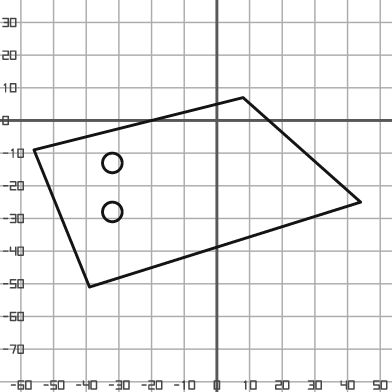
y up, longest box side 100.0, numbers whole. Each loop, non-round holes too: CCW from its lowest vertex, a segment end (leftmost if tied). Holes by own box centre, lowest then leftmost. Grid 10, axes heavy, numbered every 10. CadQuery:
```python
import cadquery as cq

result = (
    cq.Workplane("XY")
    .moveTo(-39.0, -51.0)
    .lineTo(44.0, -25.0)
    .lineTo(8.0, 7.0)
    .lineTo(-56.0, -9.0)
    .close()
    .moveTo(-32.0, -28.0)
    .circle(3.0)
    .moveTo(-32.0, -13.0)
    .circle(3.0)
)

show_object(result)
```